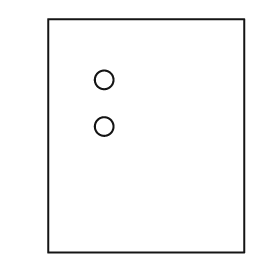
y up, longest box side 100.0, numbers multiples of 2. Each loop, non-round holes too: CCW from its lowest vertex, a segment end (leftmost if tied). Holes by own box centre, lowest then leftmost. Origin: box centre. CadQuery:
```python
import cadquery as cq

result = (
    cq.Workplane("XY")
    .moveTo(-42.0, -50.0)
    .lineTo(42.0, -50.0)
    .lineTo(42.0, 50.0)
    .lineTo(-42.0, 50.0)
    .close()
    .moveTo(-18.0, 4.0)
    .circle(4.0)
    .moveTo(-18.0, 24.0)
    .circle(4.0)
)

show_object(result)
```